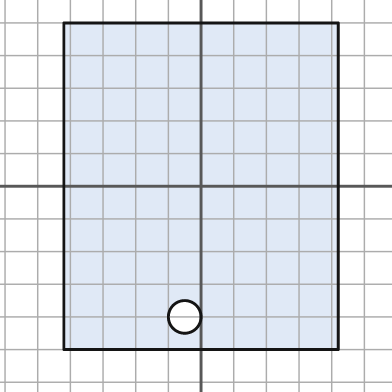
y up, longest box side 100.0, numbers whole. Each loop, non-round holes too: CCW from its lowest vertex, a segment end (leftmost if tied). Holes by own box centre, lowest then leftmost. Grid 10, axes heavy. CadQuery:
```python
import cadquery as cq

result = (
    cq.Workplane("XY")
    .moveTo(-42.0, -50.0)
    .lineTo(42.0, -50.0)
    .lineTo(42.0, 50.0)
    .lineTo(-42.0, 50.0)
    .close()
    .moveTo(-5.0, -40.0)
    .circle(5.0)
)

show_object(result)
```